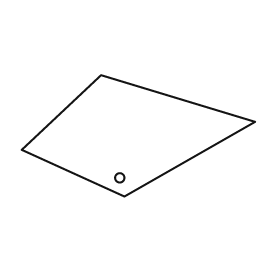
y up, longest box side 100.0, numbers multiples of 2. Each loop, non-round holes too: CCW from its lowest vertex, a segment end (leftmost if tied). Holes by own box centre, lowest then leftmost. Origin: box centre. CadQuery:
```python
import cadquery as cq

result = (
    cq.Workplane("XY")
    .moveTo(-6.0, -26.0)
    .lineTo(50.0, 6.0)
    .lineTo(-16.0, 26.0)
    .lineTo(-50.0, -6.0)
    .close()
    .moveTo(-8.0, -18.0)
    .circle(2.0)
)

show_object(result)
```